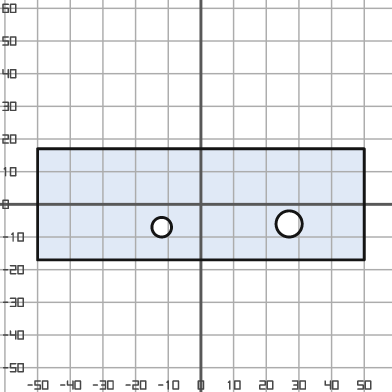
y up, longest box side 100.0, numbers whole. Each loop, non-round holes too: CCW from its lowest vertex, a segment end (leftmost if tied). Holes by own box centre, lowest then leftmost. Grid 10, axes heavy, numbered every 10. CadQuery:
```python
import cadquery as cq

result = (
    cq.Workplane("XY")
    .moveTo(-50.0, -17.0)
    .lineTo(50.0, -17.0)
    .lineTo(50.0, 17.0)
    .lineTo(-50.0, 17.0)
    .close()
    .moveTo(-12.0, -7.0)
    .circle(3.0)
    .moveTo(27.0, -6.0)
    .circle(4.0)
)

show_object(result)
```